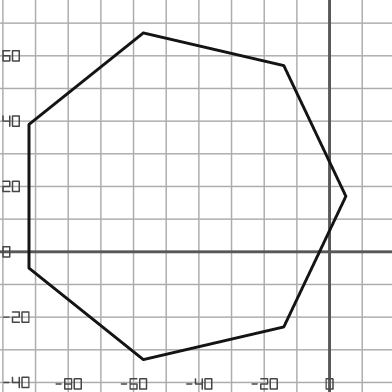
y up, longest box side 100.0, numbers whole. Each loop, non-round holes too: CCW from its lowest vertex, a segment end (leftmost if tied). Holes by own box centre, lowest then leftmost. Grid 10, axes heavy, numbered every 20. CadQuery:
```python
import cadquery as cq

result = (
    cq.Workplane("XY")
    .moveTo(-57.0, -33.0)
    .lineTo(-14.0, -23.0)
    .lineTo(5.0, 17.0)
    .lineTo(-14.0, 57.0)
    .lineTo(-57.0, 67.0)
    .lineTo(-92.0, 39.0)
    .lineTo(-92.0, -5.0)
    .close()
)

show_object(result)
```